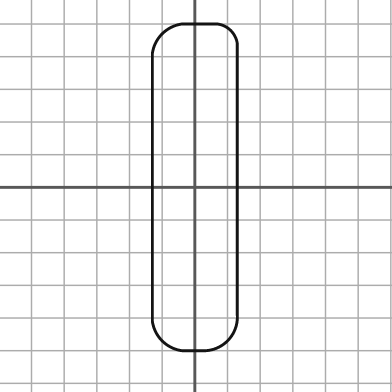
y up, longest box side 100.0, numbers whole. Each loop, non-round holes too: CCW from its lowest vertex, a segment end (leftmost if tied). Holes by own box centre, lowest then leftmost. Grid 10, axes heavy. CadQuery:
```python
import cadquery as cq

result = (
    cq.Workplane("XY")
    .moveTo(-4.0, -50.0)
    .lineTo(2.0, -50.0)
    .threePointArc((10.0, -47.0), (13.0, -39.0))
    .lineTo(13.0, 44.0)
    .threePointArc((11.0, 48.0), (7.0, 50.0))
    .lineTo(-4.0, 50.0)
    .threePointArc((-10.0, 47.0), (-13.0, 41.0))
    .lineTo(-13.0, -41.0)
    .threePointArc((-10.0, -47.0), (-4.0, -50.0))
    .close()
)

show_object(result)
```